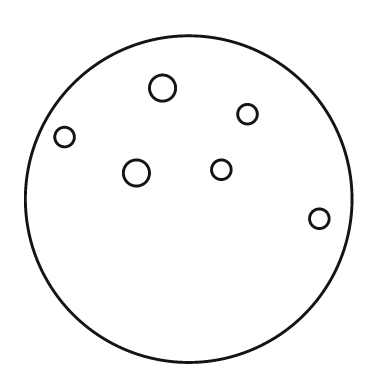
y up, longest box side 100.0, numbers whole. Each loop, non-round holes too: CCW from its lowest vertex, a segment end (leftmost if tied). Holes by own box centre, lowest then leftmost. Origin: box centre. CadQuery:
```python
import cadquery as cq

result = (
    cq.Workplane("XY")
    .moveTo(0.0, 0.0)
    .circle(50.0)
    .moveTo(40.0, -6.0)
    .circle(3.0)
    .moveTo(-16.0, 8.0)
    .circle(4.0)
    .moveTo(10.0, 9.0)
    .circle(3.0)
    .moveTo(-38.0, 19.0)
    .circle(3.0)
    .moveTo(18.0, 26.0)
    .circle(3.0)
    .moveTo(-8.0, 34.0)
    .circle(4.0)
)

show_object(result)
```